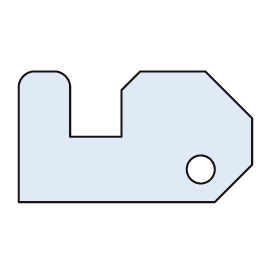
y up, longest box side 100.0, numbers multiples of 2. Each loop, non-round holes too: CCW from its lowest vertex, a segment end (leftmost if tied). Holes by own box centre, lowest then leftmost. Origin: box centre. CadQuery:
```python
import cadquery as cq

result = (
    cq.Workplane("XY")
    .moveTo(-50.0, -28.0)
    .lineTo(34.0, -28.0)
    .lineTo(50.0, -12.0)
    .lineTo(50.0, 8.0)
    .lineTo(30.0, 28.0)
    .lineTo(2.0, 28.0)
    .lineTo(-6.0, 20.0)
    .lineTo(-6.0, 0.0)
    .lineTo(-28.0, 0.0)
    .lineTo(-28.0, 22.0)
    .threePointArc((-30.0, 26.0), (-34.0, 28.0))
    .lineTo(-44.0, 28.0)
    .threePointArc((-48.0, 26.0), (-50.0, 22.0))
    .close()
    .moveTo(28.0, -14.0)
    .circle(6.0)
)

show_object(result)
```